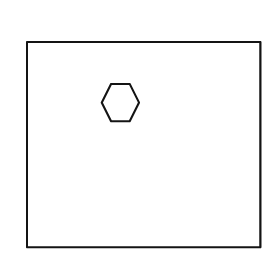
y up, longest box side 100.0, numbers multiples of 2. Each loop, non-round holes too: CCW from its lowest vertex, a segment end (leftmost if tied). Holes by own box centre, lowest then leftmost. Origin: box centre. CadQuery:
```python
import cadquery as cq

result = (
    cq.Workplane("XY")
    .moveTo(-50.0, -44.0)
    .lineTo(50.0, -44.0)
    .lineTo(50.0, 44.0)
    .lineTo(-50.0, 44.0)
    .close()
    .moveTo(-14.0, 10.0)
    .lineTo(-6.0, 10.0)
    .lineTo(-2.0, 18.0)
    .lineTo(-6.0, 26.0)
    .lineTo(-14.0, 26.0)
    .lineTo(-18.0, 18.0)
    .close()
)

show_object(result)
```